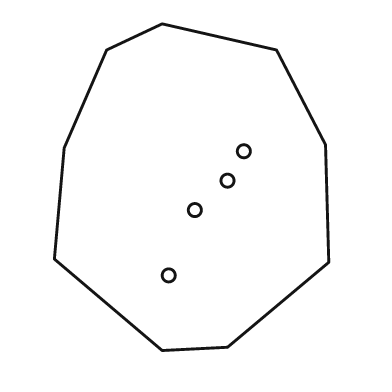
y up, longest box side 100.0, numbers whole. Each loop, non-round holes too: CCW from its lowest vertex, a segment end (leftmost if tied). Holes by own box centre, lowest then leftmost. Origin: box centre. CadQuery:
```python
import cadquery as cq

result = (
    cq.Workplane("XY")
    .moveTo(-9.0, -50.0)
    .lineTo(11.0, -49.0)
    .lineTo(42.0, -23.0)
    .lineTo(41.0, 13.0)
    .lineTo(26.0, 42.0)
    .lineTo(-9.0, 50.0)
    .lineTo(-26.0, 42.0)
    .lineTo(-39.0, 12.0)
    .lineTo(-42.0, -22.0)
    .close()
    .moveTo(-7.0, -27.0)
    .circle(2.0)
    .moveTo(1.0, -7.0)
    .circle(2.0)
    .moveTo(11.0, 2.0)
    .circle(2.0)
    .moveTo(16.0, 11.0)
    .circle(2.0)
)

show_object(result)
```